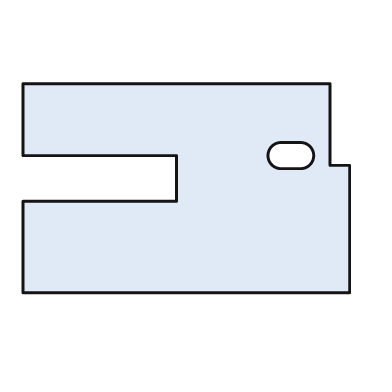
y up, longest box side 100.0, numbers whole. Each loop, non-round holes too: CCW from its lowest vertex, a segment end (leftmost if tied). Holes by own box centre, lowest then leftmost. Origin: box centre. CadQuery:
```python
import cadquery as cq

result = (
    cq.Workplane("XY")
    .moveTo(-50.0, -32.0)
    .lineTo(50.0, -32.0)
    .lineTo(50.0, 7.0)
    .lineTo(44.0, 7.0)
    .lineTo(44.0, 32.0)
    .lineTo(-50.0, 32.0)
    .lineTo(-50.0, 10.0)
    .lineTo(-3.0, 10.0)
    .lineTo(-3.0, -4.0)
    .lineTo(-50.0, -4.0)
    .close()
    .moveTo(29.0, 6.0)
    .lineTo(35.0, 6.0)
    .threePointArc((39.0, 10.0), (35.0, 14.0))
    .lineTo(29.0, 14.0)
    .threePointArc((25.0, 10.0), (29.0, 6.0))
    .close()
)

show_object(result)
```